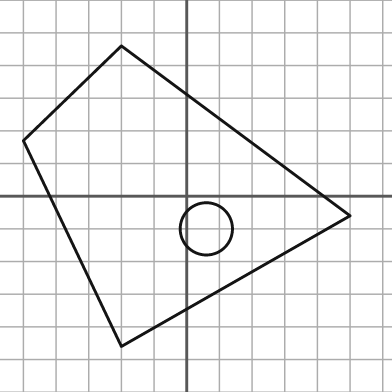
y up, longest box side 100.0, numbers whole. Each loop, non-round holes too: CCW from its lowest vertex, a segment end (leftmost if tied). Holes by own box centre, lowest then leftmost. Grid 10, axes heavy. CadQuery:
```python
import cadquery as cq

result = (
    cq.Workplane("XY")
    .moveTo(-20.0, -46.0)
    .lineTo(50.0, -6.0)
    .lineTo(-20.0, 46.0)
    .lineTo(-50.0, 17.0)
    .close()
    .moveTo(6.0, -10.0)
    .circle(8.0)
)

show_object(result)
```